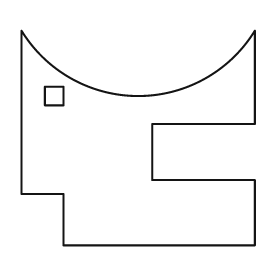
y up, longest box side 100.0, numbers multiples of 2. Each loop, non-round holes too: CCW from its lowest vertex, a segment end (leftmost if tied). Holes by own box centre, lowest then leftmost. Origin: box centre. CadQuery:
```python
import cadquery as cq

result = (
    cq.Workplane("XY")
    .moveTo(-32.0, -46.0)
    .lineTo(50.0, -46.0)
    .lineTo(50.0, -18.0)
    .lineTo(6.0, -18.0)
    .lineTo(6.0, 6.0)
    .lineTo(50.0, 6.0)
    .lineTo(50.0, 46.0)
    .threePointArc((0.0, 18.0), (-50.0, 46.0))
    .lineTo(-50.0, -24.0)
    .lineTo(-32.0, -24.0)
    .close()
    .moveTo(-40.0, 14.0)
    .lineTo(-32.0, 14.0)
    .lineTo(-32.0, 22.0)
    .lineTo(-40.0, 22.0)
    .close()
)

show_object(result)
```